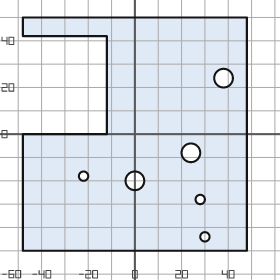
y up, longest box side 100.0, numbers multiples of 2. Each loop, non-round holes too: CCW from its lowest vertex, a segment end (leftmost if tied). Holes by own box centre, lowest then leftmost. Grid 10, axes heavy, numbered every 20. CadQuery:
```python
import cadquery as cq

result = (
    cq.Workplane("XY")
    .moveTo(-48.0, -50.0)
    .lineTo(48.0, -50.0)
    .lineTo(48.0, 50.0)
    .lineTo(-48.0, 50.0)
    .lineTo(-48.0, 42.0)
    .lineTo(-12.0, 42.0)
    .lineTo(-12.0, 0.0)
    .lineTo(-48.0, 0.0)
    .close()
    .moveTo(30.0, -44.0)
    .circle(2.0)
    .moveTo(28.0, -28.0)
    .circle(2.0)
    .moveTo(0.0, -20.0)
    .circle(4.0)
    .moveTo(-22.0, -18.0)
    .circle(2.0)
    .moveTo(24.0, -8.0)
    .circle(4.0)
    .moveTo(38.0, 24.0)
    .circle(4.0)
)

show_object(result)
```